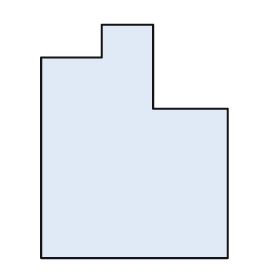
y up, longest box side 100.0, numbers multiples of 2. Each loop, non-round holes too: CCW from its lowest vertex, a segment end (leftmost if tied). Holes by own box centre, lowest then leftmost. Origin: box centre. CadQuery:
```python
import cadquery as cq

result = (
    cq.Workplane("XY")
    .moveTo(-40.0, -50.0)
    .lineTo(40.0, -50.0)
    .lineTo(40.0, 14.0)
    .lineTo(8.0, 14.0)
    .lineTo(8.0, 50.0)
    .lineTo(-14.0, 50.0)
    .lineTo(-14.0, 36.0)
    .lineTo(-40.0, 36.0)
    .close()
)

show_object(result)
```